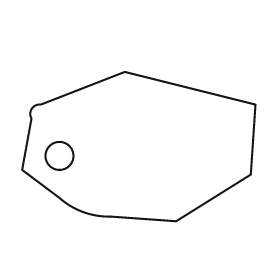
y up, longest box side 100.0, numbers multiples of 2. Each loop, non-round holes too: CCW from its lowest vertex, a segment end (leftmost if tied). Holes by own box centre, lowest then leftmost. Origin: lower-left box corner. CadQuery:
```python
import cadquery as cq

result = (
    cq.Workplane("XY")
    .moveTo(66.0, 0.0)
    .lineTo(98.0, 20.0)
    .lineTo(100.0, 50.0)
    .lineTo(44.0, 64.0)
    .lineTo(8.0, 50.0)
    .threePointArc((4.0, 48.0), (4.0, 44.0))
    .lineTo(0.0, 22.0)
    .lineTo(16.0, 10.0)
    .threePointArc((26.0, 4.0), (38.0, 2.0))
    .close()
    .moveTo(16.0, 28.0)
    .circle(6.0)
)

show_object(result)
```